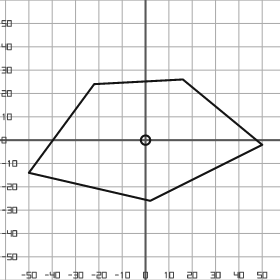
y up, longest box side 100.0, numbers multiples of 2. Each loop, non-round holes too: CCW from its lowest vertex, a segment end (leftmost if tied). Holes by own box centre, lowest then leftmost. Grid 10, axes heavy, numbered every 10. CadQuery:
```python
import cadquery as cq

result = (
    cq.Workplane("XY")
    .moveTo(2.0, -26.0)
    .lineTo(50.0, -2.0)
    .lineTo(16.0, 26.0)
    .lineTo(-22.0, 24.0)
    .lineTo(-50.0, -14.0)
    .close()
    .moveTo(0.0, 0.0)
    .circle(2.0)
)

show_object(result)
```